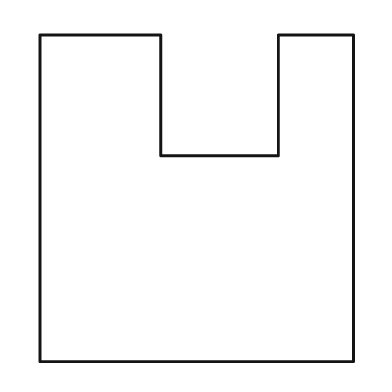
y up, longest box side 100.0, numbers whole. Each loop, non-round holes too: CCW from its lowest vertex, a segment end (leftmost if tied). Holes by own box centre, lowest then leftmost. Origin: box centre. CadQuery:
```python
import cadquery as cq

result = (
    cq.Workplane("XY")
    .moveTo(-48.0, -50.0)
    .lineTo(48.0, -50.0)
    .lineTo(48.0, 50.0)
    .lineTo(25.0, 50.0)
    .lineTo(25.0, 13.0)
    .lineTo(-11.0, 13.0)
    .lineTo(-11.0, 50.0)
    .lineTo(-48.0, 50.0)
    .close()
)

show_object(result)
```